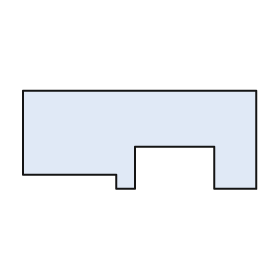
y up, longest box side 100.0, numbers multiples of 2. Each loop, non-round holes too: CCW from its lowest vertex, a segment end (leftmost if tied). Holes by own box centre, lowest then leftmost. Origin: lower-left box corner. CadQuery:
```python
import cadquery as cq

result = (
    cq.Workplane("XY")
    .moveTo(40.0, 0.0)
    .lineTo(48.0, 0.0)
    .lineTo(48.0, 18.0)
    .lineTo(82.0, 18.0)
    .lineTo(82.0, 0.0)
    .lineTo(100.0, 0.0)
    .lineTo(100.0, 42.0)
    .lineTo(0.0, 42.0)
    .lineTo(0.0, 6.0)
    .lineTo(40.0, 6.0)
    .close()
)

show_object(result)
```